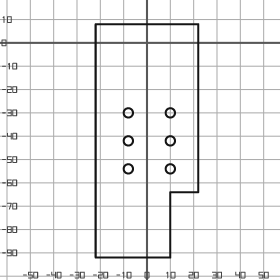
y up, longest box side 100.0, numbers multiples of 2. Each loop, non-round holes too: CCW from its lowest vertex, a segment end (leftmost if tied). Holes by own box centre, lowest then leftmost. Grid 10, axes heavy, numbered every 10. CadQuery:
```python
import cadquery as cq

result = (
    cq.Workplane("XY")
    .moveTo(-22.0, -92.0)
    .lineTo(10.0, -92.0)
    .lineTo(10.0, -64.0)
    .lineTo(22.0, -64.0)
    .lineTo(22.0, 8.0)
    .lineTo(-22.0, 8.0)
    .close()
    .moveTo(-8.0, -54.0)
    .circle(2.0)
    .moveTo(10.0, -54.0)
    .circle(2.0)
    .moveTo(-8.0, -42.0)
    .circle(2.0)
    .moveTo(10.0, -42.0)
    .circle(2.0)
    .moveTo(-8.0, -30.0)
    .circle(2.0)
    .moveTo(10.0, -30.0)
    .circle(2.0)
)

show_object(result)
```